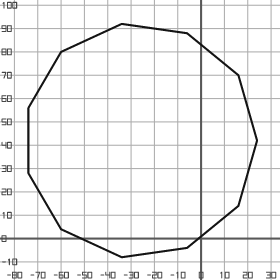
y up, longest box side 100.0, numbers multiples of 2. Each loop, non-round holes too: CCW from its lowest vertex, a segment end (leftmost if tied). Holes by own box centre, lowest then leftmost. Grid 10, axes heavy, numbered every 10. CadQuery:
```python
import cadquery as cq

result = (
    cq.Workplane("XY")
    .moveTo(-34.0, -8.0)
    .lineTo(-6.0, -4.0)
    .lineTo(16.0, 14.0)
    .lineTo(24.0, 42.0)
    .lineTo(16.0, 70.0)
    .lineTo(-6.0, 88.0)
    .lineTo(-34.0, 92.0)
    .lineTo(-60.0, 80.0)
    .lineTo(-74.0, 56.0)
    .lineTo(-74.0, 28.0)
    .lineTo(-60.0, 4.0)
    .close()
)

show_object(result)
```